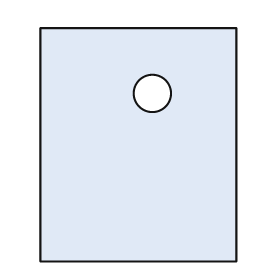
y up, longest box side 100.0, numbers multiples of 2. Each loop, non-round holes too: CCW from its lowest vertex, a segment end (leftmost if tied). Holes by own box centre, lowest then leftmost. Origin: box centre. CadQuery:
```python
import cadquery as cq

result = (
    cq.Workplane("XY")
    .moveTo(-42.0, -50.0)
    .lineTo(42.0, -50.0)
    .lineTo(42.0, 50.0)
    .lineTo(-42.0, 50.0)
    .close()
    .moveTo(6.0, 22.0)
    .circle(8.0)
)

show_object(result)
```